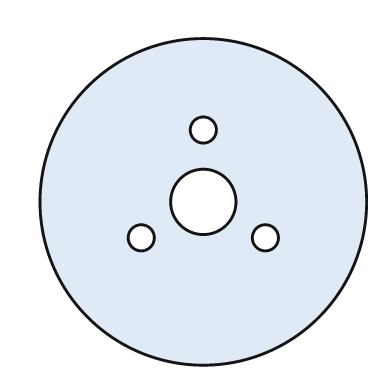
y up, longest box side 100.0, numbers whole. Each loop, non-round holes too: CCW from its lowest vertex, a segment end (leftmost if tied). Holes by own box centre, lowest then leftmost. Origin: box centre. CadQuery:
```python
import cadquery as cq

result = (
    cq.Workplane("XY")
    .moveTo(0.0, 0.0)
    .circle(50.0)
    .moveTo(-19.0, -11.0)
    .circle(4.0)
    .moveTo(19.0, -11.0)
    .circle(4.0)
    .moveTo(0.0, 0.0)
    .circle(10.0)
    .moveTo(0.0, 22.0)
    .circle(4.0)
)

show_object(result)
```